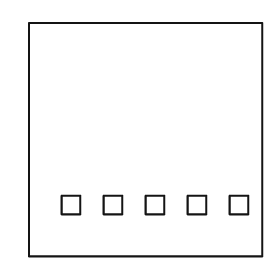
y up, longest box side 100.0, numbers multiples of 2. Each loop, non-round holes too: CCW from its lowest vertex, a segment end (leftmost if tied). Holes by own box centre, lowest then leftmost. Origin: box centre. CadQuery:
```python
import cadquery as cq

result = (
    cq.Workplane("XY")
    .moveTo(-50.0, -50.0)
    .lineTo(50.0, -50.0)
    .lineTo(50.0, 50.0)
    .lineTo(-50.0, 50.0)
    .close()
    .moveTo(-36.0, -32.0)
    .lineTo(-28.0, -32.0)
    .lineTo(-28.0, -24.0)
    .lineTo(-36.0, -24.0)
    .close()
    .moveTo(-18.0, -32.0)
    .lineTo(-10.0, -32.0)
    .lineTo(-10.0, -24.0)
    .lineTo(-18.0, -24.0)
    .close()
    .moveTo(0.0, -32.0)
    .lineTo(8.0, -32.0)
    .lineTo(8.0, -24.0)
    .lineTo(0.0, -24.0)
    .close()
    .moveTo(18.0, -32.0)
    .lineTo(26.0, -32.0)
    .lineTo(26.0, -24.0)
    .lineTo(18.0, -24.0)
    .close()
    .moveTo(36.0, -32.0)
    .lineTo(44.0, -32.0)
    .lineTo(44.0, -24.0)
    .lineTo(36.0, -24.0)
    .close()
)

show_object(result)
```